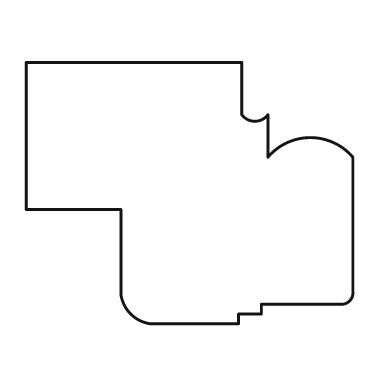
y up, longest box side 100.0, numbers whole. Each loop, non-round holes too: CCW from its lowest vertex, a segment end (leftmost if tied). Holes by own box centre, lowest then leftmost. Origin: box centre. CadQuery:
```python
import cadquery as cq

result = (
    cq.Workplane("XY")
    .moveTo(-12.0, -40.0)
    .lineTo(15.0, -40.0)
    .lineTo(15.0, -37.0)
    .lineTo(22.0, -37.0)
    .lineTo(22.0, -34.0)
    .lineTo(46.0, -34.0)
    .threePointArc((49.0, -33.0), (50.0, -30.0))
    .lineTo(50.0, 11.0)
    .threePointArc((37.0, 17.0), (24.0, 11.0))
    .lineTo(24.0, 24.0)
    .threePointArc((20.0, 22.0), (16.0, 24.0))
    .lineTo(16.0, 40.0)
    .lineTo(-50.0, 40.0)
    .lineTo(-50.0, -5.0)
    .lineTo(-21.0, -5.0)
    .lineTo(-21.0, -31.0)
    .threePointArc((-18.0, -37.0), (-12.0, -40.0))
    .close()
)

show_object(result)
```